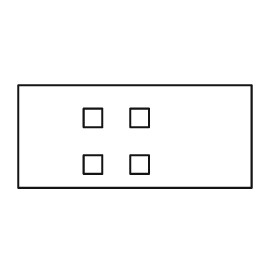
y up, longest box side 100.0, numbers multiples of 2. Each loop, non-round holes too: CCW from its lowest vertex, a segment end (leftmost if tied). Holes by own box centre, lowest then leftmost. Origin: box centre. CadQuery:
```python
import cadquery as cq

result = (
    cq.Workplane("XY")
    .moveTo(-50.0, -22.0)
    .lineTo(50.0, -22.0)
    .lineTo(50.0, 22.0)
    .lineTo(-50.0, 22.0)
    .close()
    .moveTo(-22.0, -16.0)
    .lineTo(-14.0, -16.0)
    .lineTo(-14.0, -8.0)
    .lineTo(-22.0, -8.0)
    .close()
    .moveTo(-2.0, -16.0)
    .lineTo(6.0, -16.0)
    .lineTo(6.0, -8.0)
    .lineTo(-2.0, -8.0)
    .close()
    .moveTo(-22.0, 4.0)
    .lineTo(-14.0, 4.0)
    .lineTo(-14.0, 12.0)
    .lineTo(-22.0, 12.0)
    .close()
    .moveTo(-2.0, 4.0)
    .lineTo(6.0, 4.0)
    .lineTo(6.0, 12.0)
    .lineTo(-2.0, 12.0)
    .close()
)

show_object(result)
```